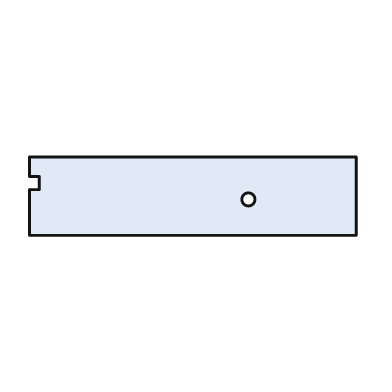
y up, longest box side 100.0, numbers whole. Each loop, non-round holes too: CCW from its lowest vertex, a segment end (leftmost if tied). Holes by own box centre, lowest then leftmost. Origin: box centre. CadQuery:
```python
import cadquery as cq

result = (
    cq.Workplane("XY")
    .moveTo(-50.0, -12.0)
    .lineTo(50.0, -12.0)
    .lineTo(50.0, 12.0)
    .lineTo(-50.0, 12.0)
    .lineTo(-50.0, 6.0)
    .lineTo(-47.0, 6.0)
    .lineTo(-47.0, 2.0)
    .lineTo(-50.0, 2.0)
    .close()
    .moveTo(17.0, -1.0)
    .circle(2.0)
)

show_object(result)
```